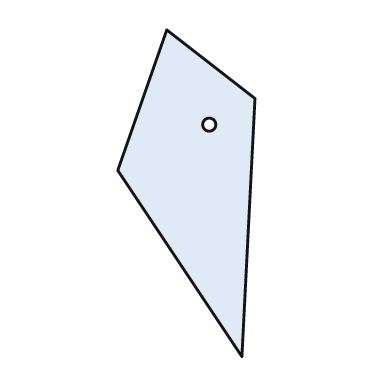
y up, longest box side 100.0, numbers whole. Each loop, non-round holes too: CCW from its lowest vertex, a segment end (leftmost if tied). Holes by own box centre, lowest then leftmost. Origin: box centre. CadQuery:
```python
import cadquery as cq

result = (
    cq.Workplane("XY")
    .moveTo(17.0, -50.0)
    .lineTo(21.0, 29.0)
    .lineTo(-6.0, 50.0)
    .lineTo(-21.0, 7.0)
    .close()
    .moveTo(7.0, 21.0)
    .circle(2.0)
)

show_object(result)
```